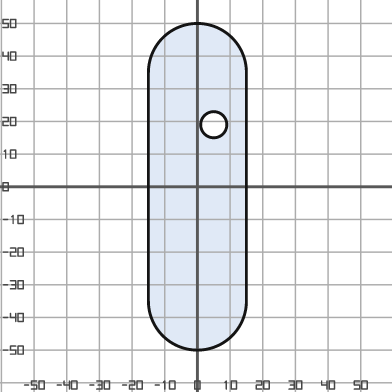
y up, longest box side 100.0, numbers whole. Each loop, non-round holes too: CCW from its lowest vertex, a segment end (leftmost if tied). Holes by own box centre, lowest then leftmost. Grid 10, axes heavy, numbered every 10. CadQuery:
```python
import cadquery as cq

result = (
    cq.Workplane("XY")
    .moveTo(-15.0, -35.0)
    .threePointArc((0.0, -50.0), (15.0, -35.0))
    .lineTo(15.0, 35.0)
    .threePointArc((0.0, 50.0), (-15.0, 35.0))
    .close()
    .moveTo(5.0, 19.0)
    .circle(4.0)
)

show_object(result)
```